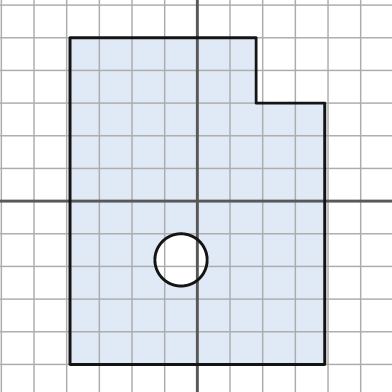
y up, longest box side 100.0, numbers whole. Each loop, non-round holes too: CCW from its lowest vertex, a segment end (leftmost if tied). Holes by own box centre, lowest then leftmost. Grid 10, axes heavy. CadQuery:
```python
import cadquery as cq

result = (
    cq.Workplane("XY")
    .moveTo(-39.0, -50.0)
    .lineTo(39.0, -50.0)
    .lineTo(39.0, 30.0)
    .lineTo(18.0, 30.0)
    .lineTo(18.0, 50.0)
    .lineTo(-39.0, 50.0)
    .close()
    .moveTo(-5.0, -18.0)
    .circle(8.0)
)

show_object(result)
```